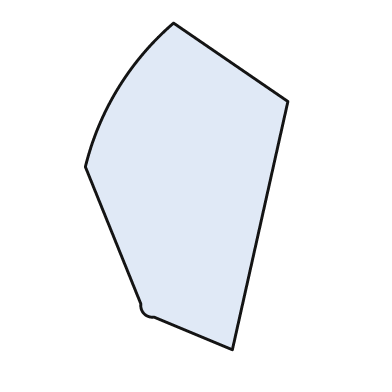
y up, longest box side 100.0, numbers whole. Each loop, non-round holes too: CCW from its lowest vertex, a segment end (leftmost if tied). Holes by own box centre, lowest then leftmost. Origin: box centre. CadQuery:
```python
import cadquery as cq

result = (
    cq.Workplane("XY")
    .moveTo(14.0, -50.0)
    .lineTo(31.0, 26.0)
    .lineTo(-4.0, 50.0)
    .threePointArc((-21.0, 30.0), (-31.0, 6.0))
    .lineTo(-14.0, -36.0)
    .threePointArc((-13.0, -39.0), (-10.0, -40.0))
    .close()
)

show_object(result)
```